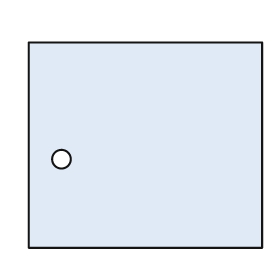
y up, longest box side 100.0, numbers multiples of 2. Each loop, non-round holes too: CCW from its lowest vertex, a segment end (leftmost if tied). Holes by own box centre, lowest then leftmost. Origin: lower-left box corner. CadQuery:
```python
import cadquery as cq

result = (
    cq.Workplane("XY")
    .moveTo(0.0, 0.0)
    .lineTo(100.0, 0.0)
    .lineTo(100.0, 88.0)
    .lineTo(0.0, 88.0)
    .close()
    .moveTo(14.0, 38.0)
    .circle(4.0)
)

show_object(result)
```